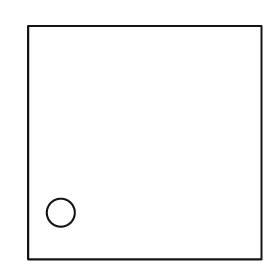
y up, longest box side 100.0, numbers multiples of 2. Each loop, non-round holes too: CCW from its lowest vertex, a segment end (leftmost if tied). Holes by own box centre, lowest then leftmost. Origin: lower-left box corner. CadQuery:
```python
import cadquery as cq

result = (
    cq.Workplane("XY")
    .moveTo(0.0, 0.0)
    .lineTo(100.0, 0.0)
    .lineTo(100.0, 100.0)
    .lineTo(0.0, 100.0)
    .close()
    .moveTo(14.0, 20.0)
    .circle(6.0)
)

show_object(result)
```